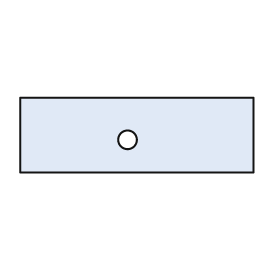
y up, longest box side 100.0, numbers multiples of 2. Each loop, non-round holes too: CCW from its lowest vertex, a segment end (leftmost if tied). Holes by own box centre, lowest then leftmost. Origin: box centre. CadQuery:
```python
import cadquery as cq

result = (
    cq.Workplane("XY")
    .moveTo(-50.0, -16.0)
    .lineTo(50.0, -16.0)
    .lineTo(50.0, 16.0)
    .lineTo(-50.0, 16.0)
    .close()
    .moveTo(-4.0, -2.0)
    .circle(4.0)
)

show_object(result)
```